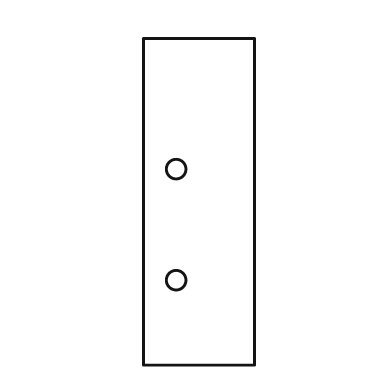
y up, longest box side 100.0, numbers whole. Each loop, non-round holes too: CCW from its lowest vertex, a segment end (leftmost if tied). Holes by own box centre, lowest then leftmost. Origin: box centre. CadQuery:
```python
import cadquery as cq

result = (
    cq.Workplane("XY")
    .moveTo(-17.0, -50.0)
    .lineTo(17.0, -50.0)
    .lineTo(17.0, 50.0)
    .lineTo(-17.0, 50.0)
    .close()
    .moveTo(-7.0, -24.0)
    .circle(3.0)
    .moveTo(-7.0, 10.0)
    .circle(3.0)
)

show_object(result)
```